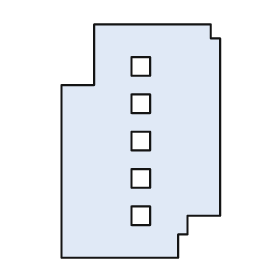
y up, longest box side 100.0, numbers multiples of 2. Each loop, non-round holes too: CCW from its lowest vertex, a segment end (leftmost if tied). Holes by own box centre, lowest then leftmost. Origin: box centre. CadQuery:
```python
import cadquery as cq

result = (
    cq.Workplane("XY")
    .moveTo(-34.0, -50.0)
    .lineTo(16.0, -50.0)
    .lineTo(16.0, -40.0)
    .lineTo(20.0, -40.0)
    .lineTo(20.0, -32.0)
    .lineTo(34.0, -32.0)
    .lineTo(34.0, 44.0)
    .lineTo(30.0, 44.0)
    .lineTo(30.0, 50.0)
    .lineTo(-20.0, 50.0)
    .lineTo(-20.0, 24.0)
    .lineTo(-34.0, 24.0)
    .close()
    .moveTo(-4.0, -36.0)
    .lineTo(4.0, -36.0)
    .lineTo(4.0, -28.0)
    .lineTo(-4.0, -28.0)
    .close()
    .moveTo(-4.0, -20.0)
    .lineTo(4.0, -20.0)
    .lineTo(4.0, -12.0)
    .lineTo(-4.0, -12.0)
    .close()
    .moveTo(-4.0, -4.0)
    .lineTo(4.0, -4.0)
    .lineTo(4.0, 4.0)
    .lineTo(-4.0, 4.0)
    .close()
    .moveTo(-4.0, 12.0)
    .lineTo(4.0, 12.0)
    .lineTo(4.0, 20.0)
    .lineTo(-4.0, 20.0)
    .close()
    .moveTo(-4.0, 28.0)
    .lineTo(4.0, 28.0)
    .lineTo(4.0, 36.0)
    .lineTo(-4.0, 36.0)
    .close()
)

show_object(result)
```